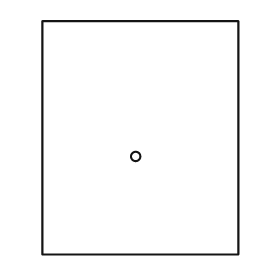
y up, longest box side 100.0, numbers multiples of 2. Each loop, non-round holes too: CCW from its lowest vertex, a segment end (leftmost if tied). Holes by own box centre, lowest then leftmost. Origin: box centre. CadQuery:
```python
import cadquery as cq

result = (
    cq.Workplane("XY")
    .moveTo(-42.0, -50.0)
    .lineTo(42.0, -50.0)
    .lineTo(42.0, 50.0)
    .lineTo(-42.0, 50.0)
    .close()
    .moveTo(-2.0, -8.0)
    .circle(2.0)
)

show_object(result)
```